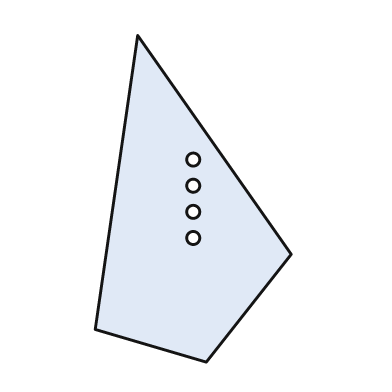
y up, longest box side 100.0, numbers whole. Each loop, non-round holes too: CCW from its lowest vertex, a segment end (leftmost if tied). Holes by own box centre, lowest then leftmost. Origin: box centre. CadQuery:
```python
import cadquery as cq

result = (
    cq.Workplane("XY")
    .moveTo(4.0, -50.0)
    .lineTo(30.0, -17.0)
    .lineTo(-17.0, 50.0)
    .lineTo(-30.0, -40.0)
    .close()
    .moveTo(0.0, -12.0)
    .circle(2.0)
    .moveTo(0.0, -4.0)
    .circle(2.0)
    .moveTo(0.0, 4.0)
    .circle(2.0)
    .moveTo(0.0, 12.0)
    .circle(2.0)
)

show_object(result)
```